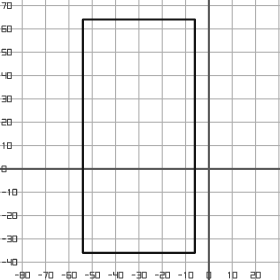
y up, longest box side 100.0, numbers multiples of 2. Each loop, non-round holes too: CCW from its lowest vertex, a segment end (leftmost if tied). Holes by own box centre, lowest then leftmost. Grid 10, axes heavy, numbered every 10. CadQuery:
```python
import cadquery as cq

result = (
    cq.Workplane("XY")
    .moveTo(-54.0, -36.0)
    .lineTo(-6.0, -36.0)
    .lineTo(-6.0, 64.0)
    .lineTo(-54.0, 64.0)
    .close()
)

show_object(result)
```